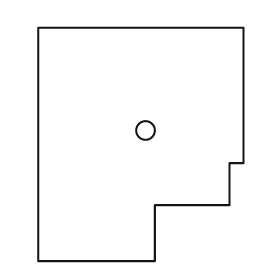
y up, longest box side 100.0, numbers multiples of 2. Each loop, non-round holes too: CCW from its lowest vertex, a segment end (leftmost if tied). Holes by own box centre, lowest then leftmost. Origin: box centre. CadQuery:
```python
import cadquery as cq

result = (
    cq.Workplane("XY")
    .moveTo(-44.0, -50.0)
    .lineTo(6.0, -50.0)
    .lineTo(6.0, -26.0)
    .lineTo(38.0, -26.0)
    .lineTo(38.0, -8.0)
    .lineTo(44.0, -8.0)
    .lineTo(44.0, 50.0)
    .lineTo(-44.0, 50.0)
    .close()
    .moveTo(2.0, 6.0)
    .circle(4.0)
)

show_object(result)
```